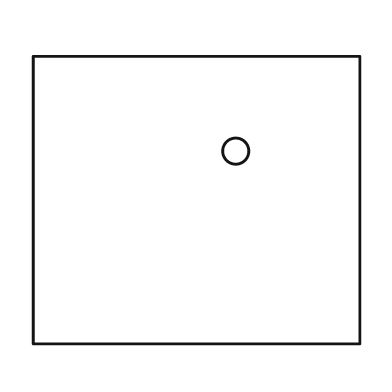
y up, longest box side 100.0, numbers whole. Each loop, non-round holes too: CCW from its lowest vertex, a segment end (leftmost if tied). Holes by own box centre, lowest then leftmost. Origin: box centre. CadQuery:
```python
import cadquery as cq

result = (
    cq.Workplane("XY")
    .moveTo(-50.0, -44.0)
    .lineTo(50.0, -44.0)
    .lineTo(50.0, 44.0)
    .lineTo(-50.0, 44.0)
    .close()
    .moveTo(12.0, 15.0)
    .circle(4.0)
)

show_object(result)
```